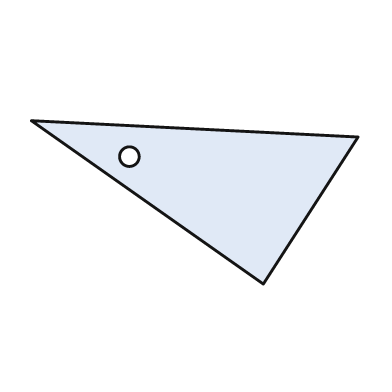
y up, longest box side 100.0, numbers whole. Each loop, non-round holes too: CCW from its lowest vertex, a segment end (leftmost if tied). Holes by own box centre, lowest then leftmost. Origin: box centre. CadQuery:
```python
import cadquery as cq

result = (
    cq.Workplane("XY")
    .moveTo(21.0, -25.0)
    .lineTo(50.0, 20.0)
    .lineTo(-50.0, 25.0)
    .close()
    .moveTo(-20.0, 14.0)
    .circle(3.0)
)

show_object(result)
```